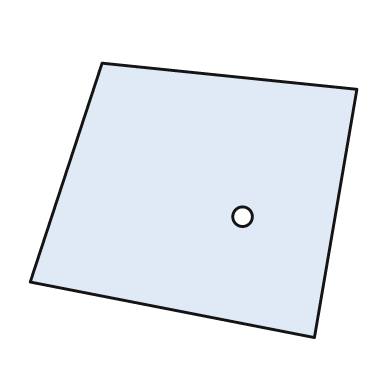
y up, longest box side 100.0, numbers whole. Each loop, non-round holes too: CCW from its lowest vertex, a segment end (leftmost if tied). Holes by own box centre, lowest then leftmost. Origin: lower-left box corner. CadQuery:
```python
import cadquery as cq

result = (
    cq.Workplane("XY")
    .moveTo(87.0, 0.0)
    .lineTo(100.0, 76.0)
    .lineTo(22.0, 84.0)
    .lineTo(0.0, 17.0)
    .close()
    .moveTo(65.0, 37.0)
    .circle(3.0)
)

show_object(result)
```